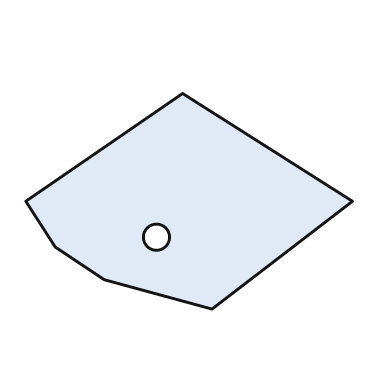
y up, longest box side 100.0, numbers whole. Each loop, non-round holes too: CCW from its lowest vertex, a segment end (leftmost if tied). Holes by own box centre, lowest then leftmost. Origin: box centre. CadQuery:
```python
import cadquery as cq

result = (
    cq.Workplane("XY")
    .moveTo(7.0, -33.0)
    .lineTo(50.0, 0.0)
    .lineTo(-2.0, 33.0)
    .lineTo(-50.0, 0.0)
    .lineTo(-41.0, -14.0)
    .lineTo(-26.0, -24.0)
    .close()
    .moveTo(-10.0, -11.0)
    .circle(4.0)
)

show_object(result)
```